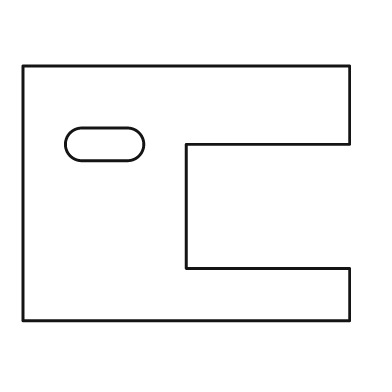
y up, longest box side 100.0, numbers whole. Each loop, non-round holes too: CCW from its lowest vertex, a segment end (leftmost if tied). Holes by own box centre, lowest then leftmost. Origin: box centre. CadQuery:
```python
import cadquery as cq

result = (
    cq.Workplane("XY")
    .moveTo(-50.0, -39.0)
    .lineTo(50.0, -39.0)
    .lineTo(50.0, -23.0)
    .lineTo(0.0, -23.0)
    .lineTo(0.0, 15.0)
    .lineTo(50.0, 15.0)
    .lineTo(50.0, 39.0)
    .lineTo(-50.0, 39.0)
    .close()
    .moveTo(-32.0, 10.0)
    .lineTo(-18.0, 10.0)
    .threePointArc((-13.0, 15.0), (-18.0, 20.0))
    .lineTo(-32.0, 20.0)
    .threePointArc((-37.0, 15.0), (-32.0, 10.0))
    .close()
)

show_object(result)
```